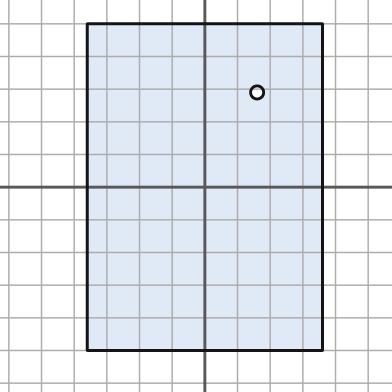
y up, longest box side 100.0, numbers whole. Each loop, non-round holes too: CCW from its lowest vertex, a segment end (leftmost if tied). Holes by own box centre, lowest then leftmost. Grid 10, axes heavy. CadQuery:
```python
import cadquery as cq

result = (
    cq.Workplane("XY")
    .moveTo(-36.0, -50.0)
    .lineTo(36.0, -50.0)
    .lineTo(36.0, 50.0)
    .lineTo(-36.0, 50.0)
    .close()
    .moveTo(16.0, 29.0)
    .circle(2.0)
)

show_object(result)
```